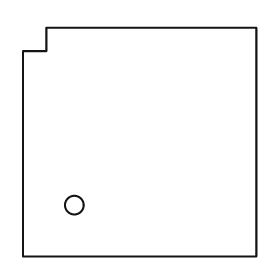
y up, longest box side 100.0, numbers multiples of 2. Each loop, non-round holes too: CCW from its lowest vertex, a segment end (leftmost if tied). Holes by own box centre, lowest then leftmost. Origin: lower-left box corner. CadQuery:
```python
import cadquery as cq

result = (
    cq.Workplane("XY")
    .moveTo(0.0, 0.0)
    .lineTo(100.0, 0.0)
    .lineTo(100.0, 98.0)
    .lineTo(10.0, 98.0)
    .lineTo(10.0, 88.0)
    .lineTo(0.0, 88.0)
    .close()
    .moveTo(22.0, 22.0)
    .circle(4.0)
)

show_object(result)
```